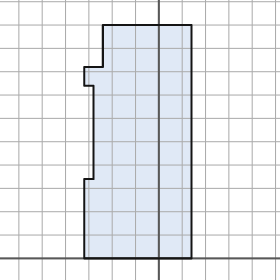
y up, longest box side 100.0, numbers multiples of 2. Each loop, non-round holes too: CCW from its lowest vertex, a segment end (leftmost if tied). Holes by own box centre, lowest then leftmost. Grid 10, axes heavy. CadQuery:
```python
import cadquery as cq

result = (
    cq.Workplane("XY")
    .moveTo(-32.0, 0.0)
    .lineTo(14.0, 0.0)
    .lineTo(14.0, 100.0)
    .lineTo(-24.0, 100.0)
    .lineTo(-24.0, 82.0)
    .lineTo(-32.0, 82.0)
    .lineTo(-32.0, 74.0)
    .lineTo(-28.0, 74.0)
    .lineTo(-28.0, 34.0)
    .lineTo(-32.0, 34.0)
    .close()
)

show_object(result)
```